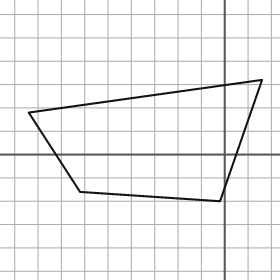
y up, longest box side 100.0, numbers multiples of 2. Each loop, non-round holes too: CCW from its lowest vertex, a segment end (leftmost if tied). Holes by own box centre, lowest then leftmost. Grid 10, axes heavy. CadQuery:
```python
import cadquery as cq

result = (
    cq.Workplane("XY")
    .moveTo(-2.0, -20.0)
    .lineTo(16.0, 32.0)
    .lineTo(-84.0, 18.0)
    .lineTo(-62.0, -16.0)
    .close()
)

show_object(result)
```